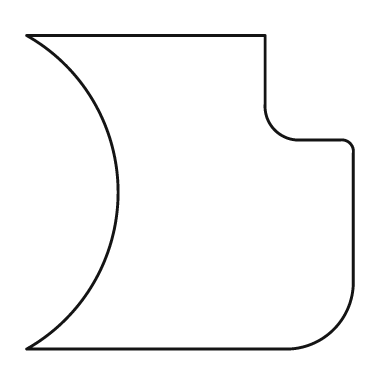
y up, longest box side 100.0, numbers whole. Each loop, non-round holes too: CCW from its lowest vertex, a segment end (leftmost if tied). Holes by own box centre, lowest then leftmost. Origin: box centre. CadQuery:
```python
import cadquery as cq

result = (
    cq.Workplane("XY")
    .moveTo(-50.0, -48.0)
    .lineTo(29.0, -48.0)
    .threePointArc((44.0, -42.0), (50.0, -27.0))
    .lineTo(50.0, 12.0)
    .threePointArc((49.0, 15.0), (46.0, 16.0))
    .lineTo(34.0, 16.0)
    .threePointArc((26.0, 19.0), (23.0, 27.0))
    .lineTo(23.0, 48.0)
    .lineTo(-50.0, 48.0)
    .threePointArc((-22.0, 0.0), (-50.0, -48.0))
    .close()
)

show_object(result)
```